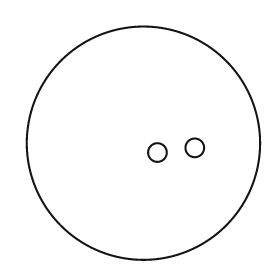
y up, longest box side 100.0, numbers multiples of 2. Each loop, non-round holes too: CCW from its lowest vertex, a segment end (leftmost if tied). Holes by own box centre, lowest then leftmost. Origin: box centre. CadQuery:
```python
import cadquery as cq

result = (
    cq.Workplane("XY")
    .moveTo(0.0, 0.0)
    .circle(50.0)
    .moveTo(6.0, -4.0)
    .circle(4.0)
    .moveTo(22.0, -2.0)
    .circle(4.0)
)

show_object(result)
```